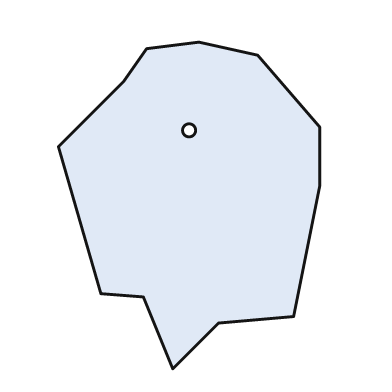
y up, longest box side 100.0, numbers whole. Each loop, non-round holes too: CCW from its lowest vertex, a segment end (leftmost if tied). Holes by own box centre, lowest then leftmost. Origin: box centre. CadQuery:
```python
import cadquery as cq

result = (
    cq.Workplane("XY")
    .moveTo(-5.0, -50.0)
    .lineTo(9.0, -36.0)
    .lineTo(32.0, -34.0)
    .lineTo(40.0, 6.0)
    .lineTo(40.0, 24.0)
    .lineTo(21.0, 46.0)
    .lineTo(3.0, 50.0)
    .lineTo(-13.0, 48.0)
    .lineTo(-20.0, 38.0)
    .lineTo(-40.0, 18.0)
    .lineTo(-27.0, -27.0)
    .lineTo(-14.0, -28.0)
    .close()
    .moveTo(0.0, 23.0)
    .circle(2.0)
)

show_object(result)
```